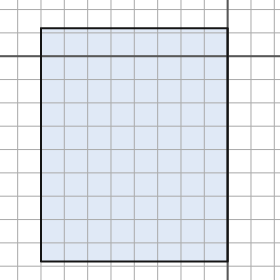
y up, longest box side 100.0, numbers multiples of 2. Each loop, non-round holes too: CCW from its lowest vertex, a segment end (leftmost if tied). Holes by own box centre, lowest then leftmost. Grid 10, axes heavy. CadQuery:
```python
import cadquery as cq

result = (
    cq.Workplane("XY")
    .moveTo(-80.0, -88.0)
    .lineTo(0.0, -88.0)
    .lineTo(0.0, 12.0)
    .lineTo(-80.0, 12.0)
    .close()
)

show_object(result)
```